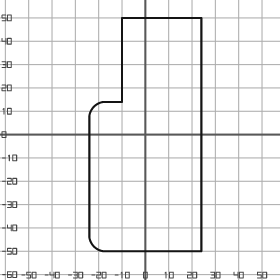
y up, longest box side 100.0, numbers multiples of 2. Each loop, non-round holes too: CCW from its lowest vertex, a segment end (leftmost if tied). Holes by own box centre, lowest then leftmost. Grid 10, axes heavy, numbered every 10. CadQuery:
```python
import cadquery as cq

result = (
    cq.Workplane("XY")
    .moveTo(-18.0, -50.0)
    .lineTo(24.0, -50.0)
    .lineTo(24.0, 50.0)
    .lineTo(-10.0, 50.0)
    .lineTo(-10.0, 14.0)
    .lineTo(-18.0, 14.0)
    .threePointArc((-22.0, 12.0), (-24.0, 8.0))
    .lineTo(-24.0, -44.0)
    .threePointArc((-22.0, -48.0), (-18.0, -50.0))
    .close()
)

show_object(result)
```